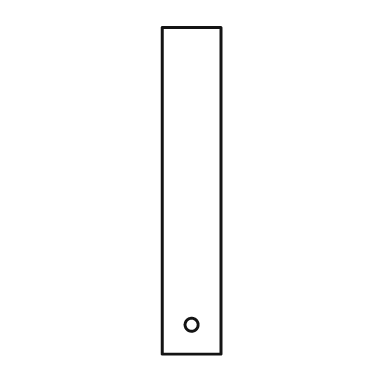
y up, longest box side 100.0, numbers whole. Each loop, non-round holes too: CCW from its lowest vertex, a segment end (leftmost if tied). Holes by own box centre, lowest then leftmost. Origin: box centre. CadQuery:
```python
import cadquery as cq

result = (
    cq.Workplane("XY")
    .moveTo(-9.0, -50.0)
    .lineTo(9.0, -50.0)
    .lineTo(9.0, 50.0)
    .lineTo(-9.0, 50.0)
    .close()
    .moveTo(0.0, -41.0)
    .circle(2.0)
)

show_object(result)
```